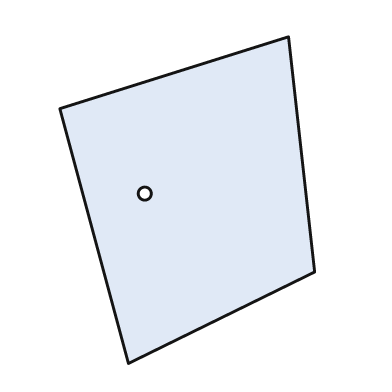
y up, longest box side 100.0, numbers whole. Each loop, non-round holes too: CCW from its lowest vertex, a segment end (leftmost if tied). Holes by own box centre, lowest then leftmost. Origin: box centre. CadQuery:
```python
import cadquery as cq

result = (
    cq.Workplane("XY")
    .moveTo(-18.0, -50.0)
    .lineTo(39.0, -22.0)
    .lineTo(31.0, 50.0)
    .lineTo(-39.0, 28.0)
    .close()
    .moveTo(-13.0, 2.0)
    .circle(2.0)
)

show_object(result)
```